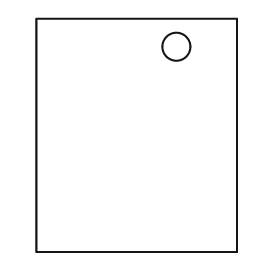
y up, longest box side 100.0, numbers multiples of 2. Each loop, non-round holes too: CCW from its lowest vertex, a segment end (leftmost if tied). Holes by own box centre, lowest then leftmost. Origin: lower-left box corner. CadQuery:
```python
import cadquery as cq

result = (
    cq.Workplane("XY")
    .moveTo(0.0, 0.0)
    .lineTo(86.0, 0.0)
    .lineTo(86.0, 100.0)
    .lineTo(0.0, 100.0)
    .close()
    .moveTo(60.0, 88.0)
    .circle(6.0)
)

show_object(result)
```